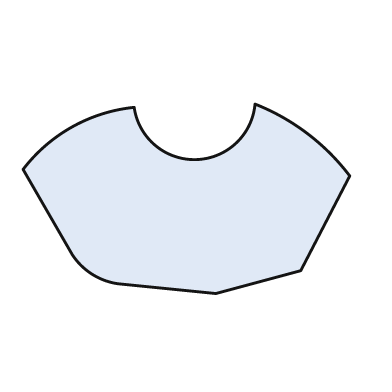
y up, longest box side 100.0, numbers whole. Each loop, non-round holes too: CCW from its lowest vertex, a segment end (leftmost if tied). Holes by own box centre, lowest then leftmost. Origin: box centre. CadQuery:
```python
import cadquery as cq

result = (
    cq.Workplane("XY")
    .moveTo(9.0, -29.0)
    .lineTo(35.0, -22.0)
    .lineTo(50.0, 7.0)
    .threePointArc((37.0, 20.0), (21.0, 29.0))
    .threePointArc((3.0, 12.0), (-16.0, 28.0))
    .threePointArc((-35.0, 22.0), (-50.0, 9.0))
    .lineTo(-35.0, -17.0)
    .threePointArc((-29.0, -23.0), (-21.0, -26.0))
    .close()
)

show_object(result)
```